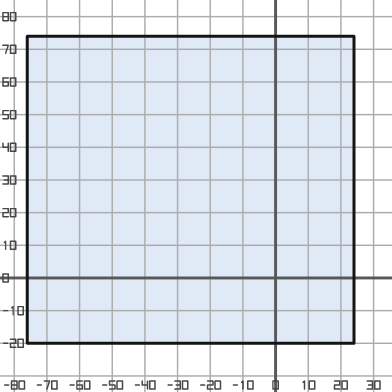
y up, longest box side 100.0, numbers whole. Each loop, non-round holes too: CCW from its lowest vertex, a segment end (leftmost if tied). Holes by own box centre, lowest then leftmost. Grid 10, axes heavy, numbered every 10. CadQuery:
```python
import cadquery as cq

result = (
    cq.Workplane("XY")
    .moveTo(-76.0, -20.0)
    .lineTo(24.0, -20.0)
    .lineTo(24.0, 74.0)
    .lineTo(-76.0, 74.0)
    .close()
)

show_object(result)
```